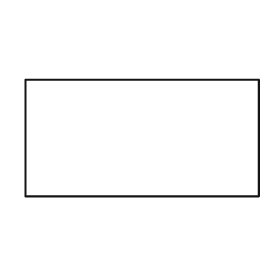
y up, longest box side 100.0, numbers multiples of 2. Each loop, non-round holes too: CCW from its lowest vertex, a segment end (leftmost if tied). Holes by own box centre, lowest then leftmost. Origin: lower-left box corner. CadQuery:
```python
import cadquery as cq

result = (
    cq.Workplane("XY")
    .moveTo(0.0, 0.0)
    .lineTo(100.0, 0.0)
    .lineTo(100.0, 50.0)
    .lineTo(0.0, 50.0)
    .close()
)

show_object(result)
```